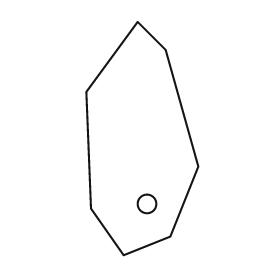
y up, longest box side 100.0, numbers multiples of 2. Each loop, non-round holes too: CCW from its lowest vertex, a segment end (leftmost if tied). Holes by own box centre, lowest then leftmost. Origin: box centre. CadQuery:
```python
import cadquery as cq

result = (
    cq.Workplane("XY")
    .moveTo(-8.0, -50.0)
    .lineTo(12.0, -42.0)
    .lineTo(24.0, -12.0)
    .lineTo(10.0, 38.0)
    .lineTo(-2.0, 50.0)
    .lineTo(-24.0, 20.0)
    .lineTo(-22.0, -30.0)
    .close()
    .moveTo(2.0, -28.0)
    .circle(4.0)
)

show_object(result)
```